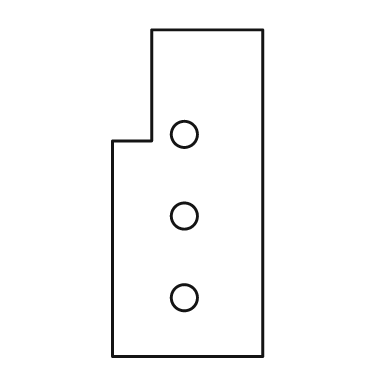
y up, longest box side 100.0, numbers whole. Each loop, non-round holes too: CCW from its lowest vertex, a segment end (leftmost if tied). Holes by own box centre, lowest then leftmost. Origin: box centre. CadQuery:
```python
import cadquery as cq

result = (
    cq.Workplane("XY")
    .moveTo(-23.0, -50.0)
    .lineTo(23.0, -50.0)
    .lineTo(23.0, 50.0)
    .lineTo(-11.0, 50.0)
    .lineTo(-11.0, 16.0)
    .lineTo(-23.0, 16.0)
    .close()
    .moveTo(-1.0, -32.0)
    .circle(4.0)
    .moveTo(-1.0, -7.0)
    .circle(4.0)
    .moveTo(-1.0, 18.0)
    .circle(4.0)
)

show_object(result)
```